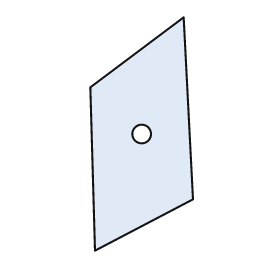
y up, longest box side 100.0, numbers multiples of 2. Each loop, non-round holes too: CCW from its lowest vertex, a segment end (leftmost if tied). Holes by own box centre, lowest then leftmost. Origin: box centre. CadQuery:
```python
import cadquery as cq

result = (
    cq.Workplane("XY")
    .moveTo(-20.0, -50.0)
    .lineTo(22.0, -28.0)
    .lineTo(18.0, 50.0)
    .lineTo(-22.0, 20.0)
    .close()
    .moveTo(0.0, 0.0)
    .circle(4.0)
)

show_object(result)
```